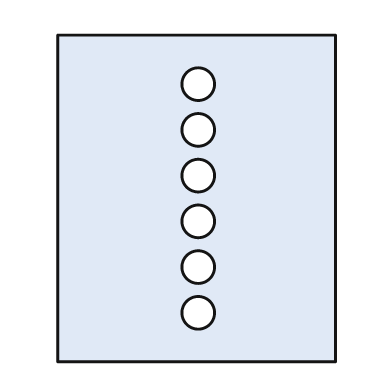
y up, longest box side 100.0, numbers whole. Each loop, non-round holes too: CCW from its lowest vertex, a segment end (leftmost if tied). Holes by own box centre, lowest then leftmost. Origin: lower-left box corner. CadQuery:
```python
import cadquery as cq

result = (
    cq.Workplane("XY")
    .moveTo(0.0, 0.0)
    .lineTo(85.0, 0.0)
    .lineTo(85.0, 100.0)
    .lineTo(0.0, 100.0)
    .close()
    .moveTo(43.0, 15.0)
    .circle(5.0)
    .moveTo(43.0, 29.0)
    .circle(5.0)
    .moveTo(43.0, 43.0)
    .circle(5.0)
    .moveTo(43.0, 57.0)
    .circle(5.0)
    .moveTo(43.0, 71.0)
    .circle(5.0)
    .moveTo(43.0, 85.0)
    .circle(5.0)
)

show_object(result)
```